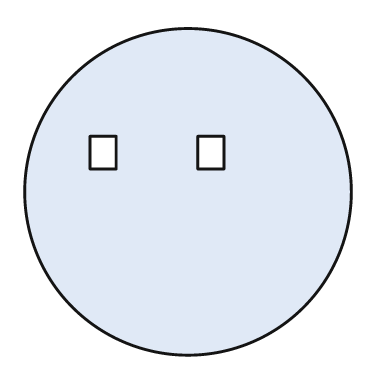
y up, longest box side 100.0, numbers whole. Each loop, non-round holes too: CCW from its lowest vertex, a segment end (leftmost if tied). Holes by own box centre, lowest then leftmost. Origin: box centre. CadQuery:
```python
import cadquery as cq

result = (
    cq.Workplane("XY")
    .moveTo(0.0, 0.0)
    .circle(50.0)
    .moveTo(-30.0, 7.0)
    .lineTo(-22.0, 7.0)
    .lineTo(-22.0, 17.0)
    .lineTo(-30.0, 17.0)
    .close()
    .moveTo(3.0, 7.0)
    .lineTo(11.0, 7.0)
    .lineTo(11.0, 17.0)
    .lineTo(3.0, 17.0)
    .close()
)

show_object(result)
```